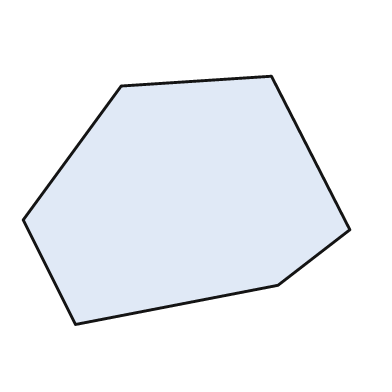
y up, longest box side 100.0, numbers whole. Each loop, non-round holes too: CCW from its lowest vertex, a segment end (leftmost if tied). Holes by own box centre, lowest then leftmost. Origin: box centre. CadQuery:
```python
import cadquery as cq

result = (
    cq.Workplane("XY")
    .moveTo(-34.0, -38.0)
    .lineTo(28.0, -26.0)
    .lineTo(50.0, -9.0)
    .lineTo(26.0, 38.0)
    .lineTo(-20.0, 35.0)
    .lineTo(-50.0, -6.0)
    .close()
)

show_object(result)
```